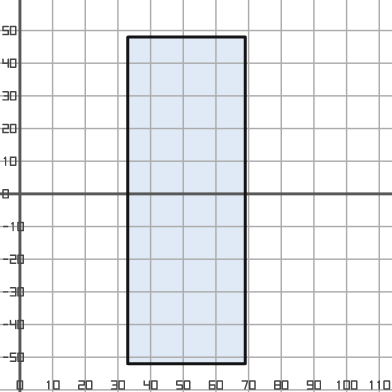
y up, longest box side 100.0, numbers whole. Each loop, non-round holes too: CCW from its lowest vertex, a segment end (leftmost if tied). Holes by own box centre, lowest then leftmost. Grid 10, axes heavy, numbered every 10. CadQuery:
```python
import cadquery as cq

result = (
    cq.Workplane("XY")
    .moveTo(33.0, -52.0)
    .lineTo(69.0, -52.0)
    .lineTo(69.0, 48.0)
    .lineTo(33.0, 48.0)
    .close()
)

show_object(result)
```